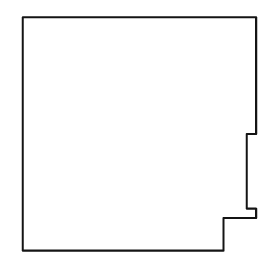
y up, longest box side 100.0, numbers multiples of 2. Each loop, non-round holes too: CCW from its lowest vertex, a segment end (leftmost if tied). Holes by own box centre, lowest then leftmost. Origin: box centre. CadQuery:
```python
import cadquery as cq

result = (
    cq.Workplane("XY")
    .moveTo(-50.0, -50.0)
    .lineTo(36.0, -50.0)
    .lineTo(36.0, -36.0)
    .lineTo(50.0, -36.0)
    .lineTo(50.0, -32.0)
    .lineTo(46.0, -32.0)
    .lineTo(46.0, 0.0)
    .lineTo(50.0, 0.0)
    .lineTo(50.0, 50.0)
    .lineTo(-50.0, 50.0)
    .close()
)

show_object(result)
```